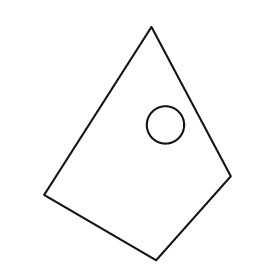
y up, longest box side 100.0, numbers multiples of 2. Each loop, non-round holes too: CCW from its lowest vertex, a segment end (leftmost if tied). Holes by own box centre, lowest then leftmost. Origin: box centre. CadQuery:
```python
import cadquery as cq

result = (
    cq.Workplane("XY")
    .moveTo(8.0, -50.0)
    .lineTo(40.0, -14.0)
    .lineTo(6.0, 50.0)
    .lineTo(-40.0, -22.0)
    .close()
    .moveTo(12.0, 8.0)
    .circle(8.0)
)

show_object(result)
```